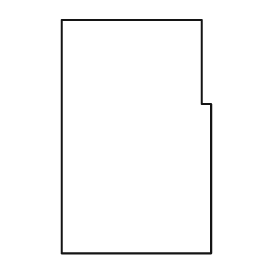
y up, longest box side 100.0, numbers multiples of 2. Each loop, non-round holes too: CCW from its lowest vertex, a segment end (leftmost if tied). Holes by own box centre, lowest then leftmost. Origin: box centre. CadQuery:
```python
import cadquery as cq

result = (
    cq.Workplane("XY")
    .moveTo(-32.0, -50.0)
    .lineTo(32.0, -50.0)
    .lineTo(32.0, 14.0)
    .lineTo(28.0, 14.0)
    .lineTo(28.0, 50.0)
    .lineTo(-32.0, 50.0)
    .close()
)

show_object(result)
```